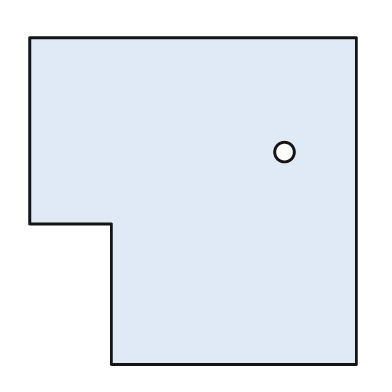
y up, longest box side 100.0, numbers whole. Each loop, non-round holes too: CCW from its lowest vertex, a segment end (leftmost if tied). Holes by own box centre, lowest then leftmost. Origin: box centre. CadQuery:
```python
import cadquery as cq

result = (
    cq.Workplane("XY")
    .moveTo(-25.0, -50.0)
    .lineTo(50.0, -50.0)
    .lineTo(50.0, 50.0)
    .lineTo(-50.0, 50.0)
    .lineTo(-50.0, -7.0)
    .lineTo(-25.0, -7.0)
    .close()
    .moveTo(28.0, 15.0)
    .circle(3.0)
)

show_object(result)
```